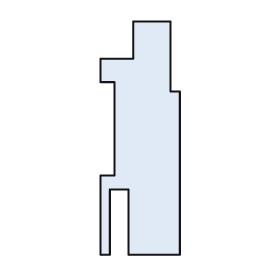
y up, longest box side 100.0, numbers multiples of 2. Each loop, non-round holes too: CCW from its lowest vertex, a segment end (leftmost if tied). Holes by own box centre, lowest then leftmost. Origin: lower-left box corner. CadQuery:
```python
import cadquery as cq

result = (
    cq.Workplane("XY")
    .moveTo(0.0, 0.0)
    .lineTo(4.0, 0.0)
    .lineTo(4.0, 28.0)
    .lineTo(12.0, 28.0)
    .lineTo(12.0, 0.0)
    .lineTo(34.0, 0.0)
    .lineTo(34.0, 70.0)
    .lineTo(30.0, 70.0)
    .lineTo(30.0, 100.0)
    .lineTo(14.0, 100.0)
    .lineTo(14.0, 84.0)
    .lineTo(0.0, 84.0)
    .lineTo(0.0, 74.0)
    .lineTo(6.0, 74.0)
    .lineTo(6.0, 34.0)
    .lineTo(0.0, 34.0)
    .close()
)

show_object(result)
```